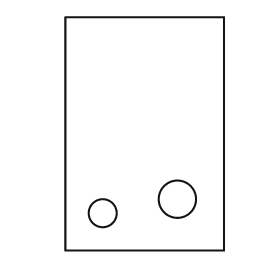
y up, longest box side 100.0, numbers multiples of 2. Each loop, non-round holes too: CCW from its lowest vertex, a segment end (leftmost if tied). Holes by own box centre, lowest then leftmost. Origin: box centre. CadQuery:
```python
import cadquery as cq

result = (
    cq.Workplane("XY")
    .moveTo(-34.0, -50.0)
    .lineTo(34.0, -50.0)
    .lineTo(34.0, 50.0)
    .lineTo(-34.0, 50.0)
    .close()
    .moveTo(-18.0, -34.0)
    .circle(6.0)
    .moveTo(14.0, -28.0)
    .circle(8.0)
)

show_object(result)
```